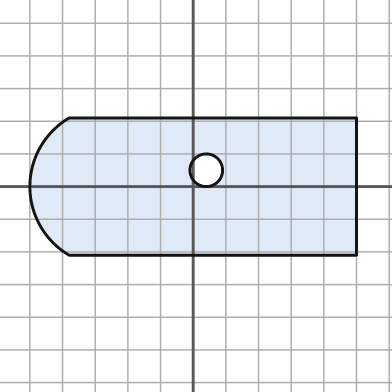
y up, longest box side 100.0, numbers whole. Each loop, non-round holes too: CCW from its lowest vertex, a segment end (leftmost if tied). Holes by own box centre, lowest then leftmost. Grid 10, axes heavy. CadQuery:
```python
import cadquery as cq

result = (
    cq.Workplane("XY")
    .moveTo(-38.0, -21.0)
    .lineTo(50.0, -21.0)
    .lineTo(50.0, 21.0)
    .lineTo(-38.0, 21.0)
    .threePointArc((-50.0, 0.0), (-38.0, -21.0))
    .close()
    .moveTo(4.0, 5.0)
    .circle(5.0)
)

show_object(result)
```